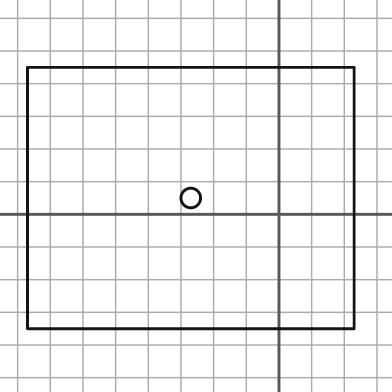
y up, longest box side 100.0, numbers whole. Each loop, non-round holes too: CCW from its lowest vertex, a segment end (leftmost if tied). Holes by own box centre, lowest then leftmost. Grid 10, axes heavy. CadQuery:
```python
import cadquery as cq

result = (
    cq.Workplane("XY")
    .moveTo(-77.0, -35.0)
    .lineTo(23.0, -35.0)
    .lineTo(23.0, 45.0)
    .lineTo(-77.0, 45.0)
    .close()
    .moveTo(-27.0, 5.0)
    .circle(3.0)
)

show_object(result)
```